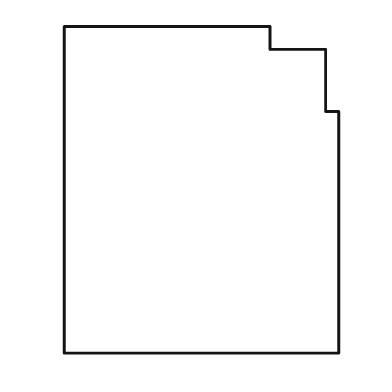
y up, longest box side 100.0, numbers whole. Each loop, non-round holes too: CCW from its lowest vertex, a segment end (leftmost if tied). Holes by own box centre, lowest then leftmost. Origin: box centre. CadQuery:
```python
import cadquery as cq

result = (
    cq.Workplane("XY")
    .moveTo(-42.0, -50.0)
    .lineTo(42.0, -50.0)
    .lineTo(42.0, 24.0)
    .lineTo(38.0, 24.0)
    .lineTo(38.0, 43.0)
    .lineTo(21.0, 43.0)
    .lineTo(21.0, 50.0)
    .lineTo(-42.0, 50.0)
    .close()
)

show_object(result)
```